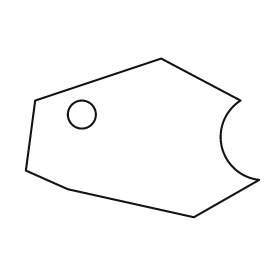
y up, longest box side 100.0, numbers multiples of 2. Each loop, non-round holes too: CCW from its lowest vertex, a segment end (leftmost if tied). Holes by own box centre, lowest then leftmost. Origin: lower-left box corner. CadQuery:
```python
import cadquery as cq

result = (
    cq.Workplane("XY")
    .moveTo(72.0, 0.0)
    .lineTo(100.0, 16.0)
    .threePointArc((84.0, 30.0), (92.0, 50.0))
    .lineTo(58.0, 68.0)
    .lineTo(4.0, 50.0)
    .lineTo(0.0, 20.0)
    .lineTo(18.0, 12.0)
    .close()
    .moveTo(24.0, 44.0)
    .circle(6.0)
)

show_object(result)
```